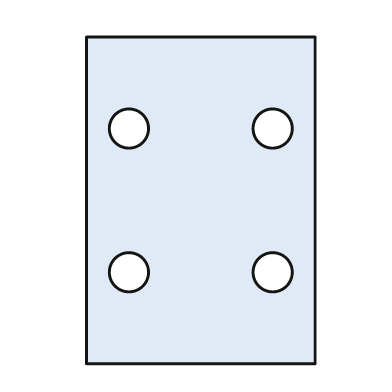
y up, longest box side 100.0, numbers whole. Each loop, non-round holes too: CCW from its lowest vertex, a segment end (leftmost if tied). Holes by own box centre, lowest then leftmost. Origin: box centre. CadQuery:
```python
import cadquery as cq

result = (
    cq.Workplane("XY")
    .moveTo(-35.0, -50.0)
    .lineTo(35.0, -50.0)
    .lineTo(35.0, 50.0)
    .lineTo(-35.0, 50.0)
    .close()
    .moveTo(-22.0, -22.0)
    .circle(6.0)
    .moveTo(22.0, -22.0)
    .circle(6.0)
    .moveTo(-22.0, 22.0)
    .circle(6.0)
    .moveTo(22.0, 22.0)
    .circle(6.0)
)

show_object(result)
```